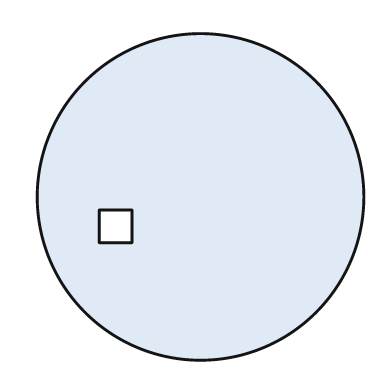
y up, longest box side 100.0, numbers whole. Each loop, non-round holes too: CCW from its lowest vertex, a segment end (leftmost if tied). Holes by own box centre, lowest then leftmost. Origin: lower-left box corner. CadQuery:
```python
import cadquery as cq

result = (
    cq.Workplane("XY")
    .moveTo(50.0, 50.0)
    .circle(50.0)
    .moveTo(19.0, 36.0)
    .lineTo(29.0, 36.0)
    .lineTo(29.0, 46.0)
    .lineTo(19.0, 46.0)
    .close()
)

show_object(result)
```